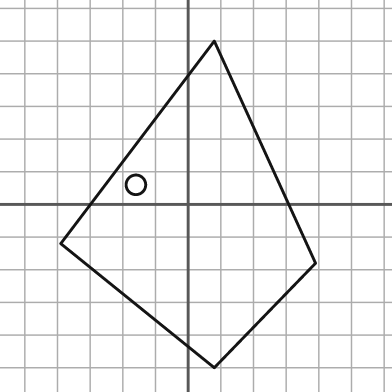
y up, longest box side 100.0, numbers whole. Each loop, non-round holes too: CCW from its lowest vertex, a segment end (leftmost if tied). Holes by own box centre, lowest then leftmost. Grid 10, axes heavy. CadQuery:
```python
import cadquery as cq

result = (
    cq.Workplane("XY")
    .moveTo(8.0, -50.0)
    .lineTo(39.0, -18.0)
    .lineTo(8.0, 50.0)
    .lineTo(-39.0, -12.0)
    .close()
    .moveTo(-16.0, 6.0)
    .circle(3.0)
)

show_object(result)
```